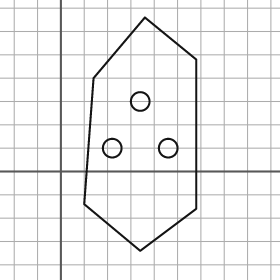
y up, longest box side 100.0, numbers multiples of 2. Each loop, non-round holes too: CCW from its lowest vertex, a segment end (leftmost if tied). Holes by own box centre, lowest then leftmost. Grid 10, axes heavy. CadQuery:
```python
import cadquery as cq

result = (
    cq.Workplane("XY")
    .moveTo(34.0, -34.0)
    .lineTo(58.0, -16.0)
    .lineTo(58.0, 48.0)
    .lineTo(36.0, 66.0)
    .lineTo(14.0, 40.0)
    .lineTo(10.0, -14.0)
    .close()
    .moveTo(22.0, 10.0)
    .circle(4.0)
    .moveTo(46.0, 10.0)
    .circle(4.0)
    .moveTo(34.0, 30.0)
    .circle(4.0)
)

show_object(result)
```